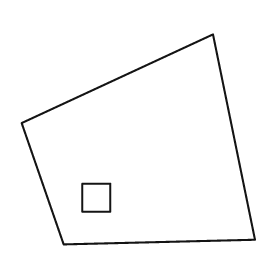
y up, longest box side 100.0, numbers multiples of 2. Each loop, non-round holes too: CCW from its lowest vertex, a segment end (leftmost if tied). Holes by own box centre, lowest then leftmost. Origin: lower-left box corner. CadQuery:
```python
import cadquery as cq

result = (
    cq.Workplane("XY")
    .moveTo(18.0, 0.0)
    .lineTo(100.0, 2.0)
    .lineTo(82.0, 90.0)
    .lineTo(0.0, 52.0)
    .close()
    .moveTo(26.0, 14.0)
    .lineTo(38.0, 14.0)
    .lineTo(38.0, 26.0)
    .lineTo(26.0, 26.0)
    .close()
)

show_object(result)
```